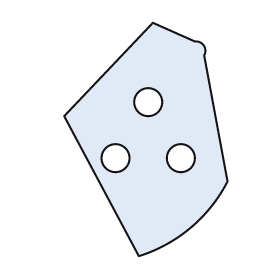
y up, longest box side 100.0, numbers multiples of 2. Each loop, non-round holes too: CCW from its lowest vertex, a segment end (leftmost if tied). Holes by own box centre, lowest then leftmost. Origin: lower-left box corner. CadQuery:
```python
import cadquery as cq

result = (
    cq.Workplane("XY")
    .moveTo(32.0, 0.0)
    .threePointArc((54.0, 12.0), (70.0, 32.0))
    .lineTo(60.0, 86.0)
    .threePointArc((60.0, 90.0), (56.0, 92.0))
    .lineTo(38.0, 100.0)
    .lineTo(0.0, 60.0)
    .close()
    .moveTo(22.0, 42.0)
    .circle(6.0)
    .moveTo(50.0, 42.0)
    .circle(6.0)
    .moveTo(36.0, 66.0)
    .circle(6.0)
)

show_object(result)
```